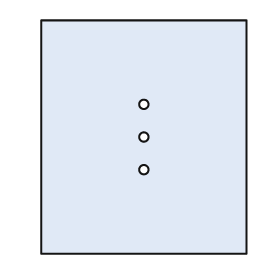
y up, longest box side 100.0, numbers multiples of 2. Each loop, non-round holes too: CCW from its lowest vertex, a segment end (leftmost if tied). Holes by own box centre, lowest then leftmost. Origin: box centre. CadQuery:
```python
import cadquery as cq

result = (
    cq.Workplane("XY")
    .moveTo(-44.0, -50.0)
    .lineTo(44.0, -50.0)
    .lineTo(44.0, 50.0)
    .lineTo(-44.0, 50.0)
    .close()
    .moveTo(0.0, -14.0)
    .circle(2.0)
    .moveTo(0.0, 0.0)
    .circle(2.0)
    .moveTo(0.0, 14.0)
    .circle(2.0)
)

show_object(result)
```